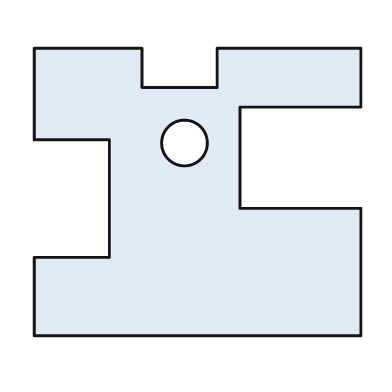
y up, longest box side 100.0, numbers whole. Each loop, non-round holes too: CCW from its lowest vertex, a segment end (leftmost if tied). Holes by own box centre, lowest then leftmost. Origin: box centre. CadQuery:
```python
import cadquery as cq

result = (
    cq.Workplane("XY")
    .moveTo(-50.0, -44.0)
    .lineTo(50.0, -44.0)
    .lineTo(50.0, -5.0)
    .lineTo(13.0, -5.0)
    .lineTo(13.0, 26.0)
    .lineTo(50.0, 26.0)
    .lineTo(50.0, 44.0)
    .lineTo(6.0, 44.0)
    .lineTo(6.0, 32.0)
    .lineTo(-17.0, 32.0)
    .lineTo(-17.0, 44.0)
    .lineTo(-50.0, 44.0)
    .lineTo(-50.0, 16.0)
    .lineTo(-27.0, 16.0)
    .lineTo(-27.0, -20.0)
    .lineTo(-50.0, -20.0)
    .close()
    .moveTo(-4.0, 15.0)
    .circle(7.0)
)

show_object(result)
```